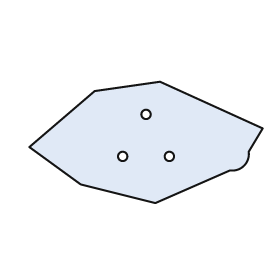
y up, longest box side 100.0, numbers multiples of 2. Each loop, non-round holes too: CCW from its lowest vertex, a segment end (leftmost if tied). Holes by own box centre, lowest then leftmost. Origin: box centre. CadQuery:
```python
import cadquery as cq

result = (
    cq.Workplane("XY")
    .moveTo(4.0, -26.0)
    .lineTo(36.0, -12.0)
    .threePointArc((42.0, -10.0), (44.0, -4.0))
    .lineTo(50.0, 6.0)
    .lineTo(6.0, 26.0)
    .lineTo(-22.0, 22.0)
    .lineTo(-50.0, -2.0)
    .lineTo(-28.0, -18.0)
    .close()
    .moveTo(-10.0, -6.0)
    .circle(2.0)
    .moveTo(10.0, -6.0)
    .circle(2.0)
    .moveTo(0.0, 12.0)
    .circle(2.0)
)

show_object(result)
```